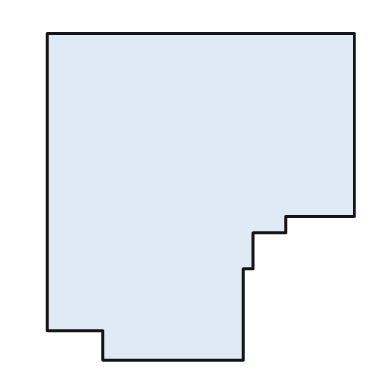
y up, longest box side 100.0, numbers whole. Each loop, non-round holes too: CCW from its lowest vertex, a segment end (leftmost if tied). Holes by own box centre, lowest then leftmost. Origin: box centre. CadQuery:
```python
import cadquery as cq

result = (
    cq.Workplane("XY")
    .moveTo(-30.0, -50.0)
    .lineTo(13.0, -50.0)
    .lineTo(13.0, -22.0)
    .lineTo(16.0, -22.0)
    .lineTo(16.0, -11.0)
    .lineTo(26.0, -11.0)
    .lineTo(26.0, -6.0)
    .lineTo(47.0, -6.0)
    .lineTo(47.0, 50.0)
    .lineTo(-47.0, 50.0)
    .lineTo(-47.0, -41.0)
    .lineTo(-30.0, -41.0)
    .close()
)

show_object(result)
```